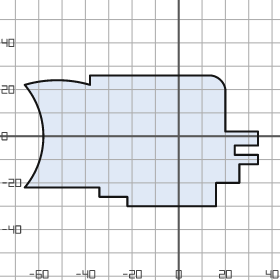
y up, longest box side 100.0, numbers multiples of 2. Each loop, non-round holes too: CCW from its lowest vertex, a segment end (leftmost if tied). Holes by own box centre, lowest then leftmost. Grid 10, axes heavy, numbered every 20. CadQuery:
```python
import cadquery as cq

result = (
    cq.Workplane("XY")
    .moveTo(-22.0, -30.0)
    .lineTo(16.0, -30.0)
    .lineTo(16.0, -20.0)
    .lineTo(26.0, -20.0)
    .lineTo(26.0, -12.0)
    .lineTo(34.0, -12.0)
    .lineTo(34.0, -8.0)
    .lineTo(24.0, -8.0)
    .lineTo(24.0, -4.0)
    .lineTo(34.0, -4.0)
    .lineTo(34.0, 2.0)
    .lineTo(20.0, 2.0)
    .lineTo(20.0, 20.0)
    .threePointArc((18.0, 24.0), (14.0, 26.0))
    .lineTo(-38.0, 26.0)
    .lineTo(-38.0, 22.0)
    .threePointArc((-52.0, 24.0), (-66.0, 22.0))
    .threePointArc((-58.0, 0.0), (-66.0, -22.0))
    .lineTo(-34.0, -22.0)
    .lineTo(-34.0, -26.0)
    .lineTo(-22.0, -26.0)
    .close()
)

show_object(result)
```